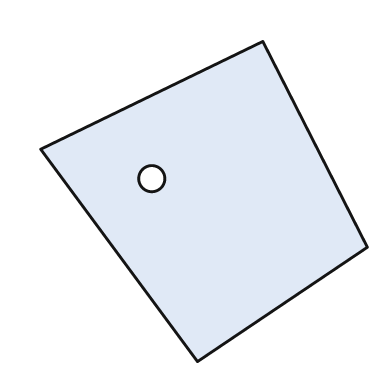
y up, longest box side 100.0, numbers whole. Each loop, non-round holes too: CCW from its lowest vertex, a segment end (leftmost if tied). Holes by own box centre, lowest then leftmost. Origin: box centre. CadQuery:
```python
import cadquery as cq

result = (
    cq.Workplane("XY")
    .moveTo(-2.0, -49.0)
    .lineTo(50.0, -14.0)
    .lineTo(18.0, 49.0)
    .lineTo(-50.0, 16.0)
    .close()
    .moveTo(-16.0, 7.0)
    .circle(4.0)
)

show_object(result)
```